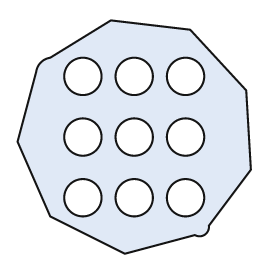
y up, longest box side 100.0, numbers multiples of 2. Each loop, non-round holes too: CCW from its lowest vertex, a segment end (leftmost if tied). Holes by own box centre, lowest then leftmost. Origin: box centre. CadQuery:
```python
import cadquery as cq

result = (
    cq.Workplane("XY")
    .moveTo(-4.0, -50.0)
    .lineTo(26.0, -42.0)
    .threePointArc((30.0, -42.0), (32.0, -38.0))
    .lineTo(50.0, -14.0)
    .lineTo(48.0, 20.0)
    .lineTo(24.0, 46.0)
    .lineTo(-10.0, 50.0)
    .lineTo(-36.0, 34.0)
    .threePointArc((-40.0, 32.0), (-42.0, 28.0))
    .lineTo(-50.0, -2.0)
    .lineTo(-36.0, -34.0)
    .close()
    .moveTo(-22.0, -26.0)
    .circle(8.0)
    .moveTo(0.0, -26.0)
    .circle(8.0)
    .moveTo(22.0, -26.0)
    .circle(8.0)
    .moveTo(-22.0, 0.0)
    .circle(8.0)
    .moveTo(0.0, 0.0)
    .circle(8.0)
    .moveTo(22.0, 0.0)
    .circle(8.0)
    .moveTo(-22.0, 26.0)
    .circle(8.0)
    .moveTo(0.0, 26.0)
    .circle(8.0)
    .moveTo(22.0, 26.0)
    .circle(8.0)
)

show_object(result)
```